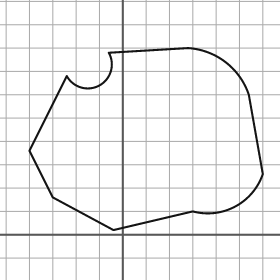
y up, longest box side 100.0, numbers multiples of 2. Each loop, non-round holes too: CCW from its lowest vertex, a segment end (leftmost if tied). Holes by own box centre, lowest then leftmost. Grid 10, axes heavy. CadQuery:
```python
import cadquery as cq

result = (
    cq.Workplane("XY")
    .moveTo(-4.0, 2.0)
    .lineTo(30.0, 10.0)
    .threePointArc((48.0, 12.0), (60.0, 26.0))
    .lineTo(54.0, 60.0)
    .threePointArc((44.0, 74.0), (28.0, 80.0))
    .lineTo(-6.0, 78.0)
    .threePointArc((-10.0, 64.0), (-24.0, 68.0))
    .lineTo(-40.0, 36.0)
    .lineTo(-30.0, 16.0)
    .close()
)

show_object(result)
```